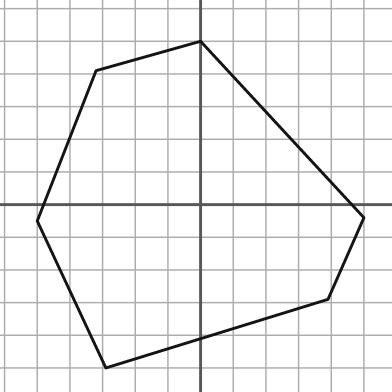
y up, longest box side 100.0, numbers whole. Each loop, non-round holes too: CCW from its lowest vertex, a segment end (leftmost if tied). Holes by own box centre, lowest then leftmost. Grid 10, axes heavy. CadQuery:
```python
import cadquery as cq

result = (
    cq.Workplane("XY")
    .moveTo(-29.0, -50.0)
    .lineTo(39.0, -29.0)
    .lineTo(50.0, -4.0)
    .lineTo(0.0, 50.0)
    .lineTo(-32.0, 41.0)
    .lineTo(-50.0, -5.0)
    .close()
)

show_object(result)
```